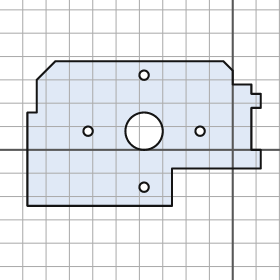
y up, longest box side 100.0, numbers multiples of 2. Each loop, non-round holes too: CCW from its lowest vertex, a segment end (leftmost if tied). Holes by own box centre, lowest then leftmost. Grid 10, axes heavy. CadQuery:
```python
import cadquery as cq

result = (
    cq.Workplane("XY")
    .moveTo(-88.0, -24.0)
    .lineTo(-26.0, -24.0)
    .lineTo(-26.0, -8.0)
    .lineTo(12.0, -8.0)
    .lineTo(12.0, 0.0)
    .lineTo(8.0, 0.0)
    .lineTo(8.0, 18.0)
    .lineTo(12.0, 18.0)
    .lineTo(12.0, 24.0)
    .lineTo(8.0, 24.0)
    .lineTo(8.0, 28.0)
    .lineTo(0.0, 28.0)
    .lineTo(0.0, 34.0)
    .lineTo(-4.0, 38.0)
    .lineTo(-76.0, 38.0)
    .lineTo(-84.0, 30.0)
    .lineTo(-84.0, 16.0)
    .lineTo(-88.0, 16.0)
    .close()
    .moveTo(-38.0, -16.0)
    .circle(2.0)
    .moveTo(-62.0, 8.0)
    .circle(2.0)
    .moveTo(-38.0, 8.0)
    .circle(8.0)
    .moveTo(-14.0, 8.0)
    .circle(2.0)
    .moveTo(-38.0, 32.0)
    .circle(2.0)
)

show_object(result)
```